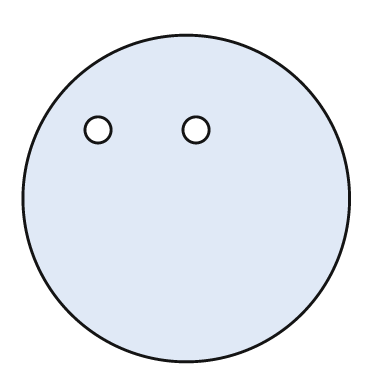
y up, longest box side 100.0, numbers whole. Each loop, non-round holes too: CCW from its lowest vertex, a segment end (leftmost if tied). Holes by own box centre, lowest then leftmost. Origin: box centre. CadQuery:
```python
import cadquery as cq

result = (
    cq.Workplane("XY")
    .moveTo(0.0, 0.0)
    .circle(50.0)
    .moveTo(-27.0, 21.0)
    .circle(4.0)
    .moveTo(3.0, 21.0)
    .circle(4.0)
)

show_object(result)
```